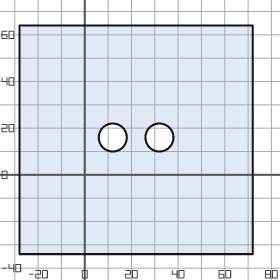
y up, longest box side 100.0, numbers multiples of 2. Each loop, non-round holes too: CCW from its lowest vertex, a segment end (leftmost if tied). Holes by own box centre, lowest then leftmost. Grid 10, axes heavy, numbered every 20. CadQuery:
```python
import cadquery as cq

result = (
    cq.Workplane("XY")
    .moveTo(-28.0, -34.0)
    .lineTo(72.0, -34.0)
    .lineTo(72.0, 64.0)
    .lineTo(-28.0, 64.0)
    .close()
    .moveTo(12.0, 16.0)
    .circle(6.0)
    .moveTo(32.0, 16.0)
    .circle(6.0)
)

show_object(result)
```